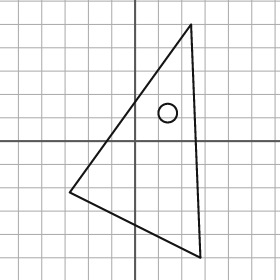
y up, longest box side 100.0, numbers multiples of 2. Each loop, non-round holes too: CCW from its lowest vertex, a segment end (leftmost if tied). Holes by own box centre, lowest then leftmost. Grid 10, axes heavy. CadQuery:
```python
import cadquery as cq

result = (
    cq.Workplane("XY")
    .moveTo(28.0, -50.0)
    .lineTo(24.0, 50.0)
    .lineTo(-28.0, -22.0)
    .close()
    .moveTo(14.0, 12.0)
    .circle(4.0)
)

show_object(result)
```